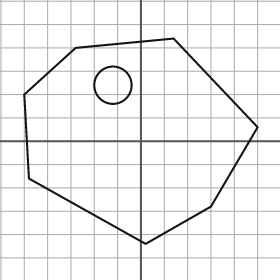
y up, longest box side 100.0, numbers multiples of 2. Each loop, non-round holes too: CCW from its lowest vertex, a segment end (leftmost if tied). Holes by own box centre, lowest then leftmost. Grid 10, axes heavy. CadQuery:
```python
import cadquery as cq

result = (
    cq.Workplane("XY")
    .moveTo(2.0, -44.0)
    .lineTo(30.0, -28.0)
    .lineTo(50.0, 6.0)
    .lineTo(14.0, 44.0)
    .lineTo(-28.0, 40.0)
    .lineTo(-50.0, 20.0)
    .lineTo(-48.0, -16.0)
    .close()
    .moveTo(-12.0, 24.0)
    .circle(8.0)
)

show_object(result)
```